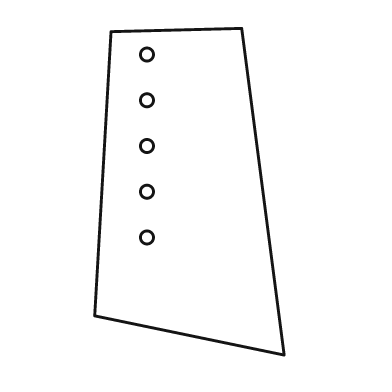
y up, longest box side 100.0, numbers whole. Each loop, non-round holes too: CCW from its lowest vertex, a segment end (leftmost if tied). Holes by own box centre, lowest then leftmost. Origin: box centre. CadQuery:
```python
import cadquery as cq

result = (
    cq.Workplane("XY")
    .moveTo(29.0, -50.0)
    .lineTo(16.0, 50.0)
    .lineTo(-24.0, 49.0)
    .lineTo(-29.0, -38.0)
    .close()
    .moveTo(-13.0, -14.0)
    .circle(2.0)
    .moveTo(-13.0, 0.0)
    .circle(2.0)
    .moveTo(-13.0, 14.0)
    .circle(2.0)
    .moveTo(-13.0, 28.0)
    .circle(2.0)
    .moveTo(-13.0, 42.0)
    .circle(2.0)
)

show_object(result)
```